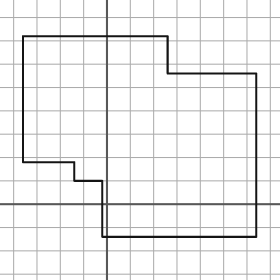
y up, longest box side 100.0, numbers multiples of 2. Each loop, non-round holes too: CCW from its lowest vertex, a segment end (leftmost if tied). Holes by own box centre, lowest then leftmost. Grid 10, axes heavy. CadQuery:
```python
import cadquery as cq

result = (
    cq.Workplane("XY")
    .moveTo(-2.0, -14.0)
    .lineTo(64.0, -14.0)
    .lineTo(64.0, 56.0)
    .lineTo(26.0, 56.0)
    .lineTo(26.0, 72.0)
    .lineTo(-36.0, 72.0)
    .lineTo(-36.0, 18.0)
    .lineTo(-14.0, 18.0)
    .lineTo(-14.0, 10.0)
    .lineTo(-2.0, 10.0)
    .close()
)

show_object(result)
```